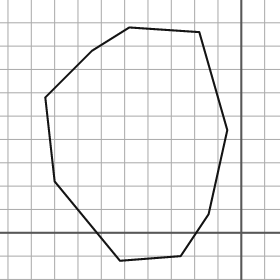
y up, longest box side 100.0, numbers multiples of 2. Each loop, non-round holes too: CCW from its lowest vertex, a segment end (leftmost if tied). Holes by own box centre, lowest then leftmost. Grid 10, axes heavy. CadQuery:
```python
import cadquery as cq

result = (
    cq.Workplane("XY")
    .moveTo(-52.0, -12.0)
    .lineTo(-26.0, -10.0)
    .lineTo(-14.0, 8.0)
    .lineTo(-6.0, 44.0)
    .lineTo(-18.0, 86.0)
    .lineTo(-48.0, 88.0)
    .lineTo(-64.0, 78.0)
    .lineTo(-84.0, 58.0)
    .lineTo(-80.0, 22.0)
    .close()
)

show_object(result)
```